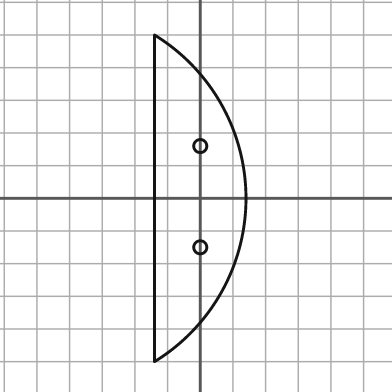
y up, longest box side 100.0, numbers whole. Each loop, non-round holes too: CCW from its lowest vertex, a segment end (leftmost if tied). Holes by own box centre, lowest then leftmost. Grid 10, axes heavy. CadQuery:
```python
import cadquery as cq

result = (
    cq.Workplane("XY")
    .moveTo(-14.0, -50.0)
    .threePointArc((14.0, 0.0), (-14.0, 50.0))
    .close()
    .moveTo(0.0, -15.0)
    .circle(2.0)
    .moveTo(0.0, 16.0)
    .circle(2.0)
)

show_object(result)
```